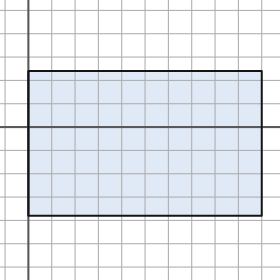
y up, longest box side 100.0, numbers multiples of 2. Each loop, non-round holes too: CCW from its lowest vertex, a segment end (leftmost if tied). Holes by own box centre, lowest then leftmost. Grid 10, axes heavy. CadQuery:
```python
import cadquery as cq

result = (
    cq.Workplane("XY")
    .moveTo(0.0, -38.0)
    .lineTo(100.0, -38.0)
    .lineTo(100.0, 24.0)
    .lineTo(0.0, 24.0)
    .close()
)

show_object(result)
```